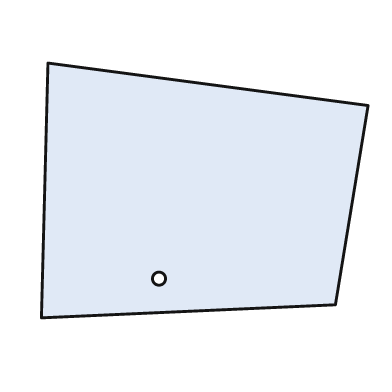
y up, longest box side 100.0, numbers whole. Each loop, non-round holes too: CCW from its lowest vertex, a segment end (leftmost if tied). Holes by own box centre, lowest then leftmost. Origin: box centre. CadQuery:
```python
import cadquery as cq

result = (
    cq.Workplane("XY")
    .moveTo(-50.0, -39.0)
    .lineTo(40.0, -35.0)
    .lineTo(50.0, 26.0)
    .lineTo(-48.0, 39.0)
    .close()
    .moveTo(-14.0, -27.0)
    .circle(2.0)
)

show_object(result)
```